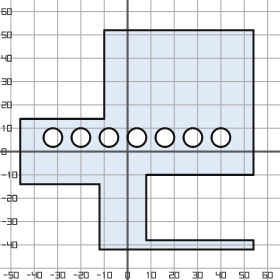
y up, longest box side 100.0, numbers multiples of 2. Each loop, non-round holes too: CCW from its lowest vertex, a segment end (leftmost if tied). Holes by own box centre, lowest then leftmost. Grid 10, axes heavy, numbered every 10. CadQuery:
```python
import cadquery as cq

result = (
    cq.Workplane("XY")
    .moveTo(-12.0, -42.0)
    .lineTo(54.0, -42.0)
    .lineTo(54.0, -38.0)
    .lineTo(8.0, -38.0)
    .lineTo(8.0, -10.0)
    .lineTo(54.0, -10.0)
    .lineTo(54.0, 52.0)
    .lineTo(-10.0, 52.0)
    .lineTo(-10.0, 14.0)
    .lineTo(-46.0, 14.0)
    .lineTo(-46.0, -14.0)
    .lineTo(-12.0, -14.0)
    .close()
    .moveTo(-32.0, 6.0)
    .circle(4.0)
    .moveTo(-20.0, 6.0)
    .circle(4.0)
    .moveTo(-8.0, 6.0)
    .circle(4.0)
    .moveTo(4.0, 6.0)
    .circle(4.0)
    .moveTo(16.0, 6.0)
    .circle(4.0)
    .moveTo(28.0, 6.0)
    .circle(4.0)
    .moveTo(40.0, 6.0)
    .circle(4.0)
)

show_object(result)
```